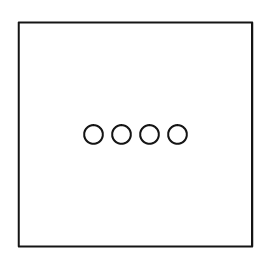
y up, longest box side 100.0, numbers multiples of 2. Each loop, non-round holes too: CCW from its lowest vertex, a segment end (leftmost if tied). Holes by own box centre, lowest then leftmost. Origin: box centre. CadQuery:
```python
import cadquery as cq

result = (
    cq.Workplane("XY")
    .moveTo(-50.0, -48.0)
    .lineTo(50.0, -48.0)
    .lineTo(50.0, 48.0)
    .lineTo(-50.0, 48.0)
    .close()
    .moveTo(-18.0, 0.0)
    .circle(4.0)
    .moveTo(-6.0, 0.0)
    .circle(4.0)
    .moveTo(6.0, 0.0)
    .circle(4.0)
    .moveTo(18.0, 0.0)
    .circle(4.0)
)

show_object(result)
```